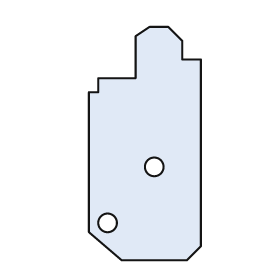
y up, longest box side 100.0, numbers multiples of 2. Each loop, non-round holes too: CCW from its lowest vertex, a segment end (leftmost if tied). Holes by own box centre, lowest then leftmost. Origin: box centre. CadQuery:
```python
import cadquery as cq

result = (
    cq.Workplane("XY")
    .moveTo(-10.0, -50.0)
    .lineTo(18.0, -50.0)
    .lineTo(24.0, -44.0)
    .lineTo(24.0, 36.0)
    .lineTo(16.0, 36.0)
    .lineTo(16.0, 44.0)
    .lineTo(10.0, 50.0)
    .lineTo(2.0, 50.0)
    .lineTo(-4.0, 46.0)
    .lineTo(-4.0, 28.0)
    .lineTo(-20.0, 28.0)
    .lineTo(-20.0, 22.0)
    .lineTo(-24.0, 22.0)
    .lineTo(-24.0, -38.0)
    .close()
    .moveTo(-16.0, -34.0)
    .circle(4.0)
    .moveTo(4.0, -10.0)
    .circle(4.0)
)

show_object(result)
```